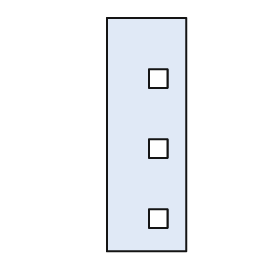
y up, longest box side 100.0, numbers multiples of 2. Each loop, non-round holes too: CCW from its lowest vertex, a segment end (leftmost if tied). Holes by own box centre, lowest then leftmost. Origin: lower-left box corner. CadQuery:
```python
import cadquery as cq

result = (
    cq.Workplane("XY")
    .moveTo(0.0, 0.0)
    .lineTo(34.0, 0.0)
    .lineTo(34.0, 100.0)
    .lineTo(0.0, 100.0)
    .close()
    .moveTo(18.0, 10.0)
    .lineTo(26.0, 10.0)
    .lineTo(26.0, 18.0)
    .lineTo(18.0, 18.0)
    .close()
    .moveTo(18.0, 40.0)
    .lineTo(26.0, 40.0)
    .lineTo(26.0, 48.0)
    .lineTo(18.0, 48.0)
    .close()
    .moveTo(18.0, 70.0)
    .lineTo(26.0, 70.0)
    .lineTo(26.0, 78.0)
    .lineTo(18.0, 78.0)
    .close()
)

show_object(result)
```